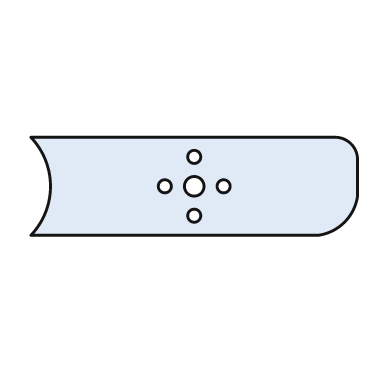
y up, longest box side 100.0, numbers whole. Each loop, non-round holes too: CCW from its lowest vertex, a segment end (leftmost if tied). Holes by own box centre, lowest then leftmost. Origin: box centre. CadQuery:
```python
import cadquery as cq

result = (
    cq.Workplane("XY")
    .moveTo(-50.0, -15.0)
    .lineTo(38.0, -15.0)
    .threePointArc((46.0, -11.0), (50.0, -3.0))
    .lineTo(50.0, 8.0)
    .threePointArc((48.0, 13.0), (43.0, 15.0))
    .lineTo(-50.0, 15.0)
    .threePointArc((-44.0, 0.0), (-50.0, -15.0))
    .close()
    .moveTo(0.0, -9.0)
    .circle(2.0)
    .moveTo(-9.0, 0.0)
    .circle(2.0)
    .moveTo(0.0, 0.0)
    .circle(3.0)
    .moveTo(9.0, 0.0)
    .circle(2.0)
    .moveTo(0.0, 9.0)
    .circle(2.0)
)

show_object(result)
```